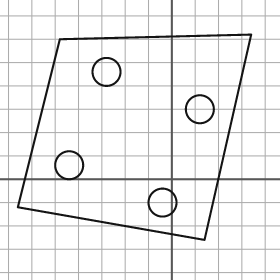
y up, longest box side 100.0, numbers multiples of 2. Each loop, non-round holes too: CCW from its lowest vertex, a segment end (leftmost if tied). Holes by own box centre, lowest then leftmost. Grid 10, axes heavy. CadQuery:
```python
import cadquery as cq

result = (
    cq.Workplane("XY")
    .moveTo(14.0, -26.0)
    .lineTo(34.0, 62.0)
    .lineTo(-48.0, 60.0)
    .lineTo(-66.0, -12.0)
    .close()
    .moveTo(-4.0, -10.0)
    .circle(6.0)
    .moveTo(-44.0, 6.0)
    .circle(6.0)
    .moveTo(12.0, 30.0)
    .circle(6.0)
    .moveTo(-28.0, 46.0)
    .circle(6.0)
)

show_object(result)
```